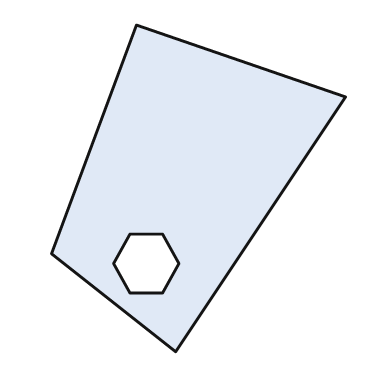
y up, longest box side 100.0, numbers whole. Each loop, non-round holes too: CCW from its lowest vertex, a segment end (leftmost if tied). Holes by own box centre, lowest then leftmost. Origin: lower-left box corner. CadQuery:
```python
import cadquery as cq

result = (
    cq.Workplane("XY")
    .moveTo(38.0, 0.0)
    .lineTo(90.0, 78.0)
    .lineTo(26.0, 100.0)
    .lineTo(0.0, 30.0)
    .close()
    .moveTo(24.0, 18.0)
    .lineTo(34.0, 18.0)
    .lineTo(39.0, 27.0)
    .lineTo(34.0, 36.0)
    .lineTo(24.0, 36.0)
    .lineTo(19.0, 27.0)
    .close()
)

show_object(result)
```